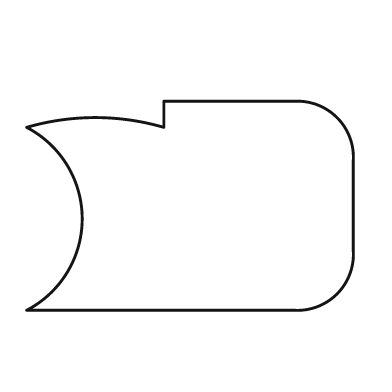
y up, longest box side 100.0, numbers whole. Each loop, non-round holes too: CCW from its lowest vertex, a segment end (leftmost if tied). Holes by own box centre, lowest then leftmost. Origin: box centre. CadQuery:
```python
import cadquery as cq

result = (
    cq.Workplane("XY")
    .moveTo(-50.0, -32.0)
    .lineTo(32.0, -32.0)
    .threePointArc((45.0, -27.0), (50.0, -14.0))
    .lineTo(50.0, 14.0)
    .threePointArc((45.0, 27.0), (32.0, 32.0))
    .lineTo(-8.0, 32.0)
    .lineTo(-8.0, 24.0)
    .threePointArc((-29.0, 27.0), (-50.0, 24.0))
    .threePointArc((-33.0, -4.0), (-50.0, -32.0))
    .close()
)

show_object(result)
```